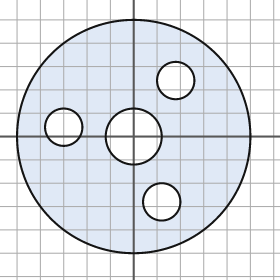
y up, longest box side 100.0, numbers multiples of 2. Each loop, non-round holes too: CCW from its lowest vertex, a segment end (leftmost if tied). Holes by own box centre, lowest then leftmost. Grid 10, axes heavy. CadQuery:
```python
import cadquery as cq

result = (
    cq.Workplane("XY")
    .moveTo(0.0, 0.0)
    .circle(50.0)
    .moveTo(12.0, -28.0)
    .circle(8.0)
    .moveTo(0.0, 0.0)
    .circle(12.0)
    .moveTo(-30.0, 4.0)
    .circle(8.0)
    .moveTo(18.0, 24.0)
    .circle(8.0)
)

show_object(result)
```